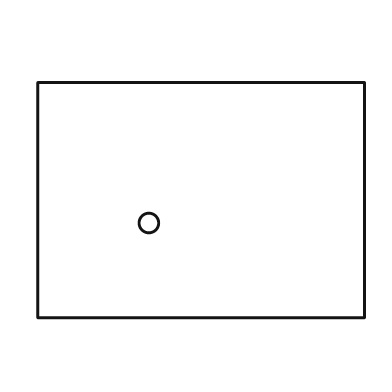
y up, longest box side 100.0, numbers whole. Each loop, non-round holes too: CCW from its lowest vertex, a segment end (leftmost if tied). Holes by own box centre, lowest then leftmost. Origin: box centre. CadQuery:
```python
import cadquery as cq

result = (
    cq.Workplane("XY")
    .moveTo(-50.0, -36.0)
    .lineTo(50.0, -36.0)
    .lineTo(50.0, 36.0)
    .lineTo(-50.0, 36.0)
    .close()
    .moveTo(-16.0, -7.0)
    .circle(3.0)
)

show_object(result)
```